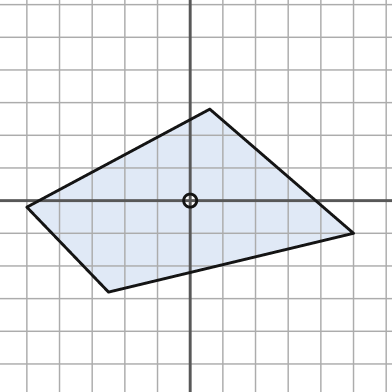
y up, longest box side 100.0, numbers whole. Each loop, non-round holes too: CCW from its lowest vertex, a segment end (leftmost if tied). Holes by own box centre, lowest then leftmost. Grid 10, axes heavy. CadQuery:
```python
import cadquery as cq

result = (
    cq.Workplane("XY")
    .moveTo(-25.0, -28.0)
    .lineTo(50.0, -10.0)
    .lineTo(6.0, 28.0)
    .lineTo(-50.0, -2.0)
    .close()
    .moveTo(0.0, 0.0)
    .circle(2.0)
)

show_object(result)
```